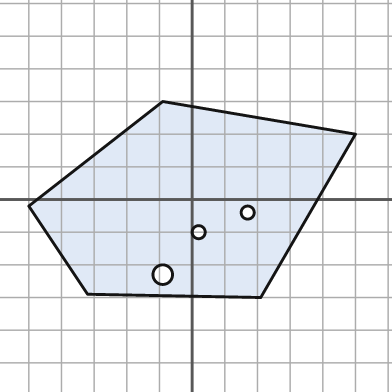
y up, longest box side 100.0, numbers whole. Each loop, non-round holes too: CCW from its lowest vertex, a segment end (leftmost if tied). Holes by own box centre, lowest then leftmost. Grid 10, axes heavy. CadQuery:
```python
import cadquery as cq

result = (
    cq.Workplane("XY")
    .moveTo(21.0, -30.0)
    .lineTo(50.0, 20.0)
    .lineTo(-9.0, 30.0)
    .lineTo(-50.0, -2.0)
    .lineTo(-32.0, -29.0)
    .close()
    .moveTo(-9.0, -23.0)
    .circle(3.0)
    .moveTo(2.0, -10.0)
    .circle(2.0)
    .moveTo(17.0, -4.0)
    .circle(2.0)
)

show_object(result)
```